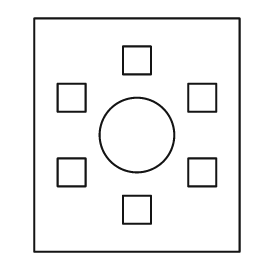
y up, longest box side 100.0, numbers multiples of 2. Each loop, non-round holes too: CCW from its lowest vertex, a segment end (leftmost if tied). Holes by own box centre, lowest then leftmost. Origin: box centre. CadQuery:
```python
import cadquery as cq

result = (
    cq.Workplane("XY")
    .moveTo(-44.0, -50.0)
    .lineTo(44.0, -50.0)
    .lineTo(44.0, 50.0)
    .lineTo(-44.0, 50.0)
    .close()
    .moveTo(-6.0, -38.0)
    .lineTo(6.0, -38.0)
    .lineTo(6.0, -26.0)
    .lineTo(-6.0, -26.0)
    .close()
    .moveTo(-34.0, -22.0)
    .lineTo(-22.0, -22.0)
    .lineTo(-22.0, -10.0)
    .lineTo(-34.0, -10.0)
    .close()
    .moveTo(22.0, -22.0)
    .lineTo(34.0, -22.0)
    .lineTo(34.0, -10.0)
    .lineTo(22.0, -10.0)
    .close()
    .moveTo(0.0, 0.0)
    .circle(16.0)
    .moveTo(-34.0, 10.0)
    .lineTo(-22.0, 10.0)
    .lineTo(-22.0, 22.0)
    .lineTo(-34.0, 22.0)
    .close()
    .moveTo(22.0, 10.0)
    .lineTo(34.0, 10.0)
    .lineTo(34.0, 22.0)
    .lineTo(22.0, 22.0)
    .close()
    .moveTo(-6.0, 26.0)
    .lineTo(6.0, 26.0)
    .lineTo(6.0, 38.0)
    .lineTo(-6.0, 38.0)
    .close()
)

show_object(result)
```